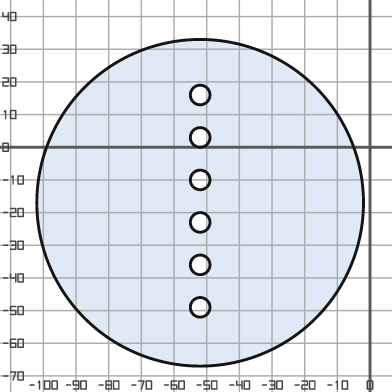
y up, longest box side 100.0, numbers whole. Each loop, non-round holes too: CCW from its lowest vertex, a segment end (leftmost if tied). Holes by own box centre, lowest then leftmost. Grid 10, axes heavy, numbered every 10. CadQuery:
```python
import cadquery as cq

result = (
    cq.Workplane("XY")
    .moveTo(-52.0, -17.0)
    .circle(50.0)
    .moveTo(-52.0, -49.0)
    .circle(3.0)
    .moveTo(-52.0, -36.0)
    .circle(3.0)
    .moveTo(-52.0, -23.0)
    .circle(3.0)
    .moveTo(-52.0, -10.0)
    .circle(3.0)
    .moveTo(-52.0, 3.0)
    .circle(3.0)
    .moveTo(-52.0, 16.0)
    .circle(3.0)
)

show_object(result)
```